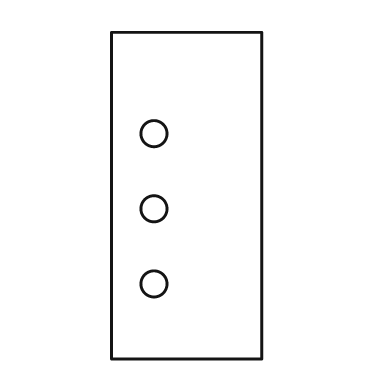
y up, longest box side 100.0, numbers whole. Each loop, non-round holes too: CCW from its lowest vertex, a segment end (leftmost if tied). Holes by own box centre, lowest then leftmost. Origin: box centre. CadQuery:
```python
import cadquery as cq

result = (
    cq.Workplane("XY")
    .moveTo(-23.0, -50.0)
    .lineTo(23.0, -50.0)
    .lineTo(23.0, 50.0)
    .lineTo(-23.0, 50.0)
    .close()
    .moveTo(-10.0, -27.0)
    .circle(4.0)
    .moveTo(-10.0, -4.0)
    .circle(4.0)
    .moveTo(-10.0, 19.0)
    .circle(4.0)
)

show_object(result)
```